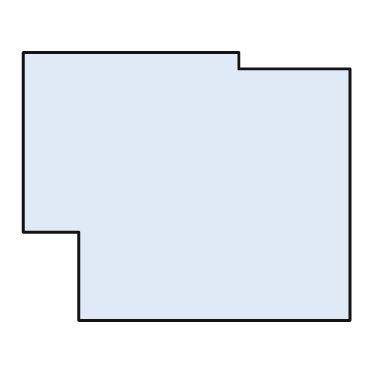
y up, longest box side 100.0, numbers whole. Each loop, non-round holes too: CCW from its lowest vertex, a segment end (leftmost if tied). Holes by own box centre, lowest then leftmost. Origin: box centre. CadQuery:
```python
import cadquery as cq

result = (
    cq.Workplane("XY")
    .moveTo(-33.0, -41.0)
    .lineTo(50.0, -41.0)
    .lineTo(50.0, 36.0)
    .lineTo(16.0, 36.0)
    .lineTo(16.0, 41.0)
    .lineTo(-50.0, 41.0)
    .lineTo(-50.0, -14.0)
    .lineTo(-33.0, -14.0)
    .close()
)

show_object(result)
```